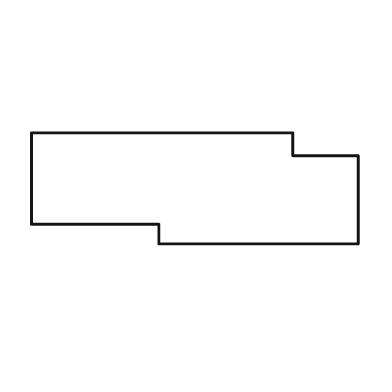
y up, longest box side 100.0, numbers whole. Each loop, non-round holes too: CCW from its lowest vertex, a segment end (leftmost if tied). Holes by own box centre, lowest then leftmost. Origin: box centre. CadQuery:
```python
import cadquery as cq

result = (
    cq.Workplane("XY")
    .moveTo(-11.0, -17.0)
    .lineTo(50.0, -17.0)
    .lineTo(50.0, 10.0)
    .lineTo(30.0, 10.0)
    .lineTo(30.0, 17.0)
    .lineTo(-50.0, 17.0)
    .lineTo(-50.0, -11.0)
    .lineTo(-11.0, -11.0)
    .close()
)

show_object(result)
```